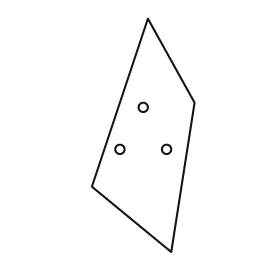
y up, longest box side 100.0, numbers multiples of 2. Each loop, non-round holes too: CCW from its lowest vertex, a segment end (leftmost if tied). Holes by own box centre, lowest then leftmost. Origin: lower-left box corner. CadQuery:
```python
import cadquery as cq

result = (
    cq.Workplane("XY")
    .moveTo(34.0, 0.0)
    .lineTo(44.0, 64.0)
    .lineTo(24.0, 100.0)
    .lineTo(0.0, 28.0)
    .close()
    .moveTo(12.0, 44.0)
    .circle(2.0)
    .moveTo(32.0, 44.0)
    .circle(2.0)
    .moveTo(22.0, 62.0)
    .circle(2.0)
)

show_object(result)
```